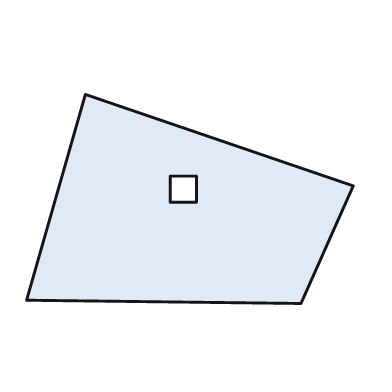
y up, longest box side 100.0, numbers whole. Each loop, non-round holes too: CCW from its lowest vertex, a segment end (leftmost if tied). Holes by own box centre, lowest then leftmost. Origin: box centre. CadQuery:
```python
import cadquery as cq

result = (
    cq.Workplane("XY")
    .moveTo(34.0, -32.0)
    .lineTo(50.0, 4.0)
    .lineTo(-32.0, 32.0)
    .lineTo(-50.0, -31.0)
    .close()
    .moveTo(-6.0, -1.0)
    .lineTo(2.0, -1.0)
    .lineTo(2.0, 7.0)
    .lineTo(-6.0, 7.0)
    .close()
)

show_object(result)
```